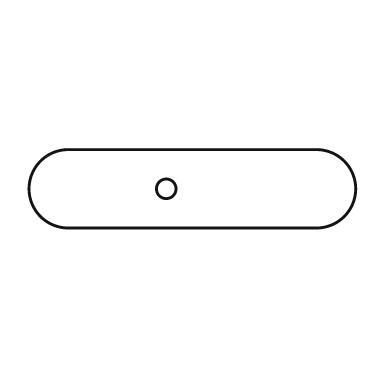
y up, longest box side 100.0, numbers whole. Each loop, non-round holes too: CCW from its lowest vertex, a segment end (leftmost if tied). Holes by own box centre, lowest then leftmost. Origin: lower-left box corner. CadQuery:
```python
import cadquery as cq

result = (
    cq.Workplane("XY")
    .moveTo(12.0, 0.0)
    .lineTo(88.0, 0.0)
    .threePointArc((100.0, 12.0), (88.0, 24.0))
    .lineTo(12.0, 24.0)
    .threePointArc((0.0, 12.0), (12.0, 0.0))
    .close()
    .moveTo(42.0, 12.0)
    .circle(3.0)
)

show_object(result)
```